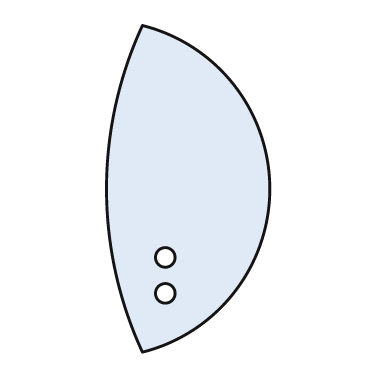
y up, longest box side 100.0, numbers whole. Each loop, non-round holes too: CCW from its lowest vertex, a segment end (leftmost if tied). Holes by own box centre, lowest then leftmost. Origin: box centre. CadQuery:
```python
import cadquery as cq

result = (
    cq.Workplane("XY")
    .moveTo(-14.0, -50.0)
    .threePointArc((25.0, 0.0), (-14.0, 50.0))
    .threePointArc((-25.0, 0.0), (-14.0, -50.0))
    .close()
    .moveTo(-7.0, -32.0)
    .circle(3.0)
    .moveTo(-7.0, -21.0)
    .circle(3.0)
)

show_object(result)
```